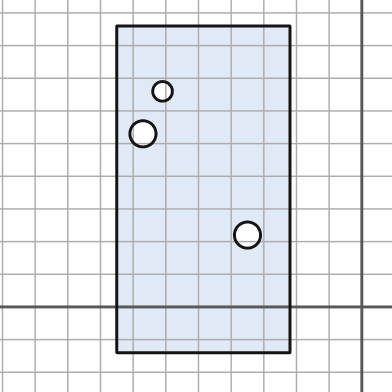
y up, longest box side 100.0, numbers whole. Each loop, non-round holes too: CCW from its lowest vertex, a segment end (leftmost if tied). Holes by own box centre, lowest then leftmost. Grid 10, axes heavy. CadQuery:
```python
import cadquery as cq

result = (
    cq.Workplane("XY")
    .moveTo(-75.0, -14.0)
    .lineTo(-22.0, -14.0)
    .lineTo(-22.0, 86.0)
    .lineTo(-75.0, 86.0)
    .close()
    .moveTo(-35.0, 22.0)
    .circle(4.0)
    .moveTo(-67.0, 53.0)
    .circle(4.0)
    .moveTo(-61.0, 66.0)
    .circle(3.0)
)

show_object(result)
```